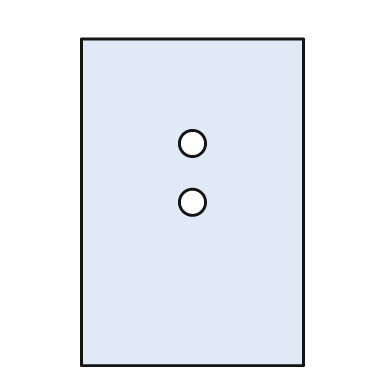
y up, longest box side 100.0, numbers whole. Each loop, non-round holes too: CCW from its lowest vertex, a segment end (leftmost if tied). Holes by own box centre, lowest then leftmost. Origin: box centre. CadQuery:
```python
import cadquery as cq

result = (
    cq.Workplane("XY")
    .moveTo(-34.0, -50.0)
    .lineTo(34.0, -50.0)
    .lineTo(34.0, 50.0)
    .lineTo(-34.0, 50.0)
    .close()
    .moveTo(0.0, 0.0)
    .circle(4.0)
    .moveTo(0.0, 18.0)
    .circle(4.0)
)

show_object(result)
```